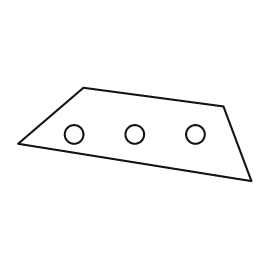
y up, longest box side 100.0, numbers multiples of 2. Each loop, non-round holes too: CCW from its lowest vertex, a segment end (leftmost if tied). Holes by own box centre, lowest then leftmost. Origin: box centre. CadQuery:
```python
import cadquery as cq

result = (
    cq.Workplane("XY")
    .moveTo(50.0, -20.0)
    .lineTo(38.0, 12.0)
    .lineTo(-22.0, 20.0)
    .lineTo(-50.0, -4.0)
    .close()
    .moveTo(-26.0, 0.0)
    .circle(4.0)
    .moveTo(0.0, 0.0)
    .circle(4.0)
    .moveTo(26.0, 0.0)
    .circle(4.0)
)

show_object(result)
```